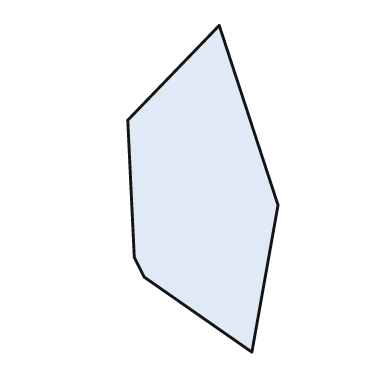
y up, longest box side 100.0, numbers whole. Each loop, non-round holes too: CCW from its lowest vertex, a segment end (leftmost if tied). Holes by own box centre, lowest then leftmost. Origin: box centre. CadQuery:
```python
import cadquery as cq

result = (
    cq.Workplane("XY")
    .moveTo(15.0, -50.0)
    .lineTo(23.0, -5.0)
    .lineTo(5.0, 50.0)
    .lineTo(-23.0, 21.0)
    .lineTo(-21.0, -21.0)
    .lineTo(-18.0, -27.0)
    .close()
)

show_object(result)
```